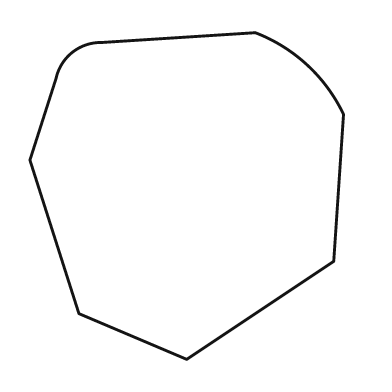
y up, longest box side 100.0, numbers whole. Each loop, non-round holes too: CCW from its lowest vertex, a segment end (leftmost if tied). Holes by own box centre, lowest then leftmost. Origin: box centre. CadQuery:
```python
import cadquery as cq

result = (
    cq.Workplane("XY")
    .moveTo(0.0, -50.0)
    .lineTo(45.0, -20.0)
    .lineTo(48.0, 25.0)
    .threePointArc((37.0, 40.0), (21.0, 50.0))
    .lineTo(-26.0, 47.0)
    .threePointArc((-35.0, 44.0), (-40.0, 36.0))
    .lineTo(-48.0, 11.0)
    .lineTo(-33.0, -36.0)
    .close()
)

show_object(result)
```